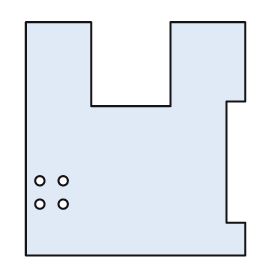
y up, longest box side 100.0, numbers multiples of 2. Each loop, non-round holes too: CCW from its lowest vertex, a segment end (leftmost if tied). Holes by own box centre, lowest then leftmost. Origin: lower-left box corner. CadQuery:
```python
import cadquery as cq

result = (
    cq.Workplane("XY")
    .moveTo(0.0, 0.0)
    .lineTo(94.0, 0.0)
    .lineTo(94.0, 14.0)
    .lineTo(86.0, 14.0)
    .lineTo(86.0, 66.0)
    .lineTo(94.0, 66.0)
    .lineTo(94.0, 100.0)
    .lineTo(62.0, 100.0)
    .lineTo(62.0, 64.0)
    .lineTo(28.0, 64.0)
    .lineTo(28.0, 100.0)
    .lineTo(0.0, 100.0)
    .close()
    .moveTo(6.0, 22.0)
    .circle(2.0)
    .moveTo(16.0, 22.0)
    .circle(2.0)
    .moveTo(6.0, 32.0)
    .circle(2.0)
    .moveTo(16.0, 32.0)
    .circle(2.0)
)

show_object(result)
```